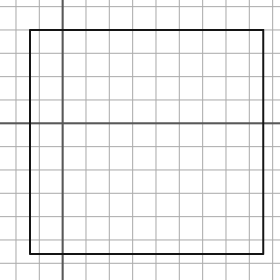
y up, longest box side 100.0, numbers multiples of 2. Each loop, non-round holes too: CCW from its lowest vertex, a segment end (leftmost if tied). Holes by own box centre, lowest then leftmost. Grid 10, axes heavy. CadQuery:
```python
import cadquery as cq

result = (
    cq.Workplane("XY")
    .moveTo(-14.0, -56.0)
    .lineTo(86.0, -56.0)
    .lineTo(86.0, 40.0)
    .lineTo(-14.0, 40.0)
    .close()
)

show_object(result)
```